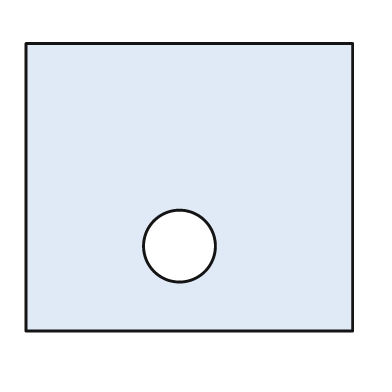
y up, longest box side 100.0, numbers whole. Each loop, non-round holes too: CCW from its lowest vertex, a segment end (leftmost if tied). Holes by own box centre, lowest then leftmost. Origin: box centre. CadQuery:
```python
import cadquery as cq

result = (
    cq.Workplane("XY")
    .moveTo(-50.0, -44.0)
    .lineTo(50.0, -44.0)
    .lineTo(50.0, 44.0)
    .lineTo(-50.0, 44.0)
    .close()
    .moveTo(-3.0, -18.0)
    .circle(11.0)
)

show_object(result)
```